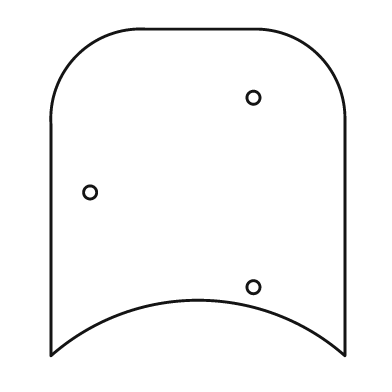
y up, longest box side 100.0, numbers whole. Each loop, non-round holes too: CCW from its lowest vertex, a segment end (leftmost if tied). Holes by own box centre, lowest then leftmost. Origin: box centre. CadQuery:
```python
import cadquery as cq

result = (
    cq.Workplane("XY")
    .moveTo(-45.0, -50.0)
    .threePointArc((0.0, -33.0), (45.0, -50.0))
    .lineTo(45.0, 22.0)
    .threePointArc((37.0, 42.0), (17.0, 50.0))
    .lineTo(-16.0, 50.0)
    .threePointArc((-37.0, 42.0), (-45.0, 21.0))
    .close()
    .moveTo(17.0, -29.0)
    .circle(2.0)
    .moveTo(-33.0, 0.0)
    .circle(2.0)
    .moveTo(17.0, 29.0)
    .circle(2.0)
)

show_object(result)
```